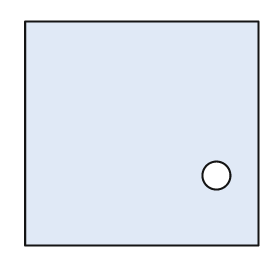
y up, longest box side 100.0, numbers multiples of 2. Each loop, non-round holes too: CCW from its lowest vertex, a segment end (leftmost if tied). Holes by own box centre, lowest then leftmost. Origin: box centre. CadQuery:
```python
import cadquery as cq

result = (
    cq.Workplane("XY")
    .moveTo(-50.0, -48.0)
    .lineTo(50.0, -48.0)
    .lineTo(50.0, 48.0)
    .lineTo(-50.0, 48.0)
    .close()
    .moveTo(32.0, -18.0)
    .circle(6.0)
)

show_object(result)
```